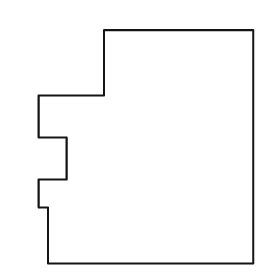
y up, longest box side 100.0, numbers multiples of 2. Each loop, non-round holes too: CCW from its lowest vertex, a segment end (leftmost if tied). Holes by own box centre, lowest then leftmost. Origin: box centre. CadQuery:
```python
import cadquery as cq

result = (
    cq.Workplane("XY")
    .moveTo(-42.0, -50.0)
    .lineTo(46.0, -50.0)
    .lineTo(46.0, 50.0)
    .lineTo(-18.0, 50.0)
    .lineTo(-18.0, 22.0)
    .lineTo(-46.0, 22.0)
    .lineTo(-46.0, 4.0)
    .lineTo(-34.0, 4.0)
    .lineTo(-34.0, -14.0)
    .lineTo(-46.0, -14.0)
    .lineTo(-46.0, -26.0)
    .lineTo(-42.0, -26.0)
    .close()
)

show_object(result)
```